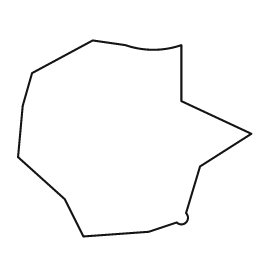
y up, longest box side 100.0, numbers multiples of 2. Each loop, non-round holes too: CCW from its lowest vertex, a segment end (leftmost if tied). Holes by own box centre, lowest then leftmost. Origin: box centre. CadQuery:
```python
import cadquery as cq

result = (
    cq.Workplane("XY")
    .moveTo(-22.0, -42.0)
    .lineTo(6.0, -40.0)
    .lineTo(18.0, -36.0)
    .threePointArc((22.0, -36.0), (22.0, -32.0))
    .lineTo(28.0, -12.0)
    .lineTo(50.0, 2.0)
    .lineTo(20.0, 16.0)
    .lineTo(20.0, 40.0)
    .threePointArc((8.0, 38.0), (-4.0, 40.0))
    .lineTo(-18.0, 42.0)
    .lineTo(-44.0, 28.0)
    .lineTo(-48.0, 14.0)
    .lineTo(-50.0, -8.0)
    .lineTo(-30.0, -26.0)
    .close()
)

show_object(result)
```